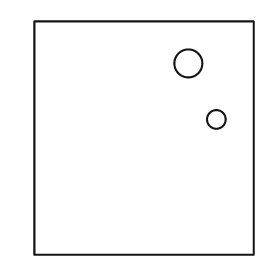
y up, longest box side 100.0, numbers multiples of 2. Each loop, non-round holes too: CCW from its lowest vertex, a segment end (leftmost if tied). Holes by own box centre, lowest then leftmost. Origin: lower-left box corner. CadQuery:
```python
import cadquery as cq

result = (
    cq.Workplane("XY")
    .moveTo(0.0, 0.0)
    .lineTo(94.0, 0.0)
    .lineTo(94.0, 100.0)
    .lineTo(0.0, 100.0)
    .close()
    .moveTo(78.0, 58.0)
    .circle(4.0)
    .moveTo(66.0, 82.0)
    .circle(6.0)
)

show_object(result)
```